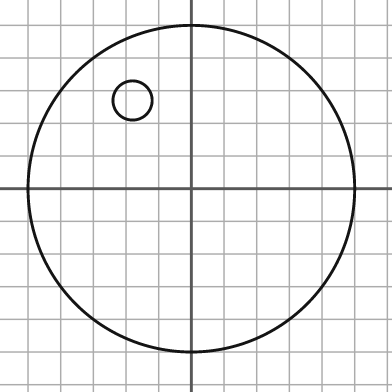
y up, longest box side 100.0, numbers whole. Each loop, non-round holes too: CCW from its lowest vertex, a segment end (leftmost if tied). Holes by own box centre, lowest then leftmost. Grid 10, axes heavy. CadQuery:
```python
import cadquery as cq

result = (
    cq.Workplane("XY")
    .moveTo(0.0, 0.0)
    .circle(50.0)
    .moveTo(-18.0, 27.0)
    .circle(6.0)
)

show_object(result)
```